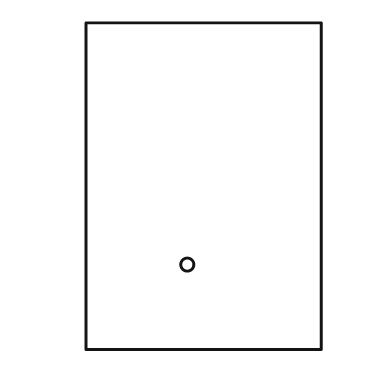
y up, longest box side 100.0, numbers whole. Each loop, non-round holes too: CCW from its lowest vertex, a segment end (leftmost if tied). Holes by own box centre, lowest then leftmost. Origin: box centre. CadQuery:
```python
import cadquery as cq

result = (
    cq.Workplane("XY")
    .moveTo(-36.0, -50.0)
    .lineTo(36.0, -50.0)
    .lineTo(36.0, 50.0)
    .lineTo(-36.0, 50.0)
    .close()
    .moveTo(-5.0, -24.0)
    .circle(2.0)
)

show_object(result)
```